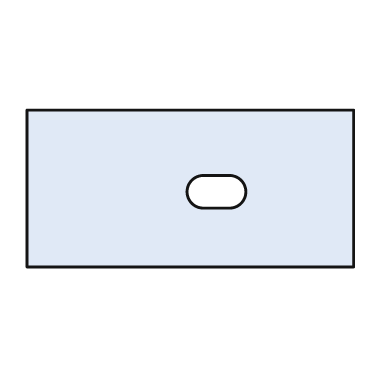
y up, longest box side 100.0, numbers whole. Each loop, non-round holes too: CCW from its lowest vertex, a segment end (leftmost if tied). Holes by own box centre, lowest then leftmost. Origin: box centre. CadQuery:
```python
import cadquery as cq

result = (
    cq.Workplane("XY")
    .moveTo(-50.0, -24.0)
    .lineTo(50.0, -24.0)
    .lineTo(50.0, 24.0)
    .lineTo(-50.0, 24.0)
    .close()
    .moveTo(4.0, -6.0)
    .lineTo(12.0, -6.0)
    .threePointArc((17.0, -1.0), (12.0, 4.0))
    .lineTo(4.0, 4.0)
    .threePointArc((-1.0, -1.0), (4.0, -6.0))
    .close()
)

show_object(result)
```